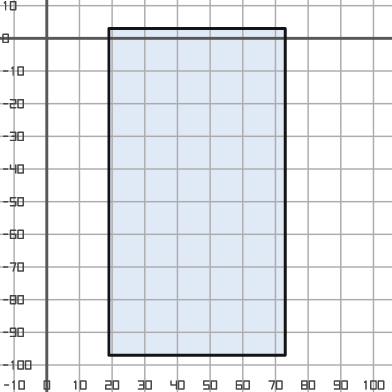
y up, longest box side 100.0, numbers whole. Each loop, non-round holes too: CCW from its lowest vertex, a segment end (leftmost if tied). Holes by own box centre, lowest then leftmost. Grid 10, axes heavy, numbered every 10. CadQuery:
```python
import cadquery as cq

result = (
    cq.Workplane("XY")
    .moveTo(19.0, -97.0)
    .lineTo(73.0, -97.0)
    .lineTo(73.0, 3.0)
    .lineTo(19.0, 3.0)
    .close()
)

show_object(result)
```